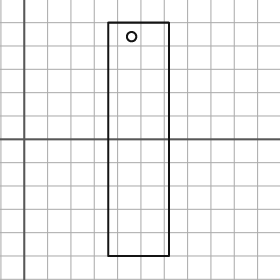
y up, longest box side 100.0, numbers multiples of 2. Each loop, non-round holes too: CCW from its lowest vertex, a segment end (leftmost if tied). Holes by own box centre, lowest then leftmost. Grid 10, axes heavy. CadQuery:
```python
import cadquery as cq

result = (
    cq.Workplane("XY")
    .moveTo(36.0, -50.0)
    .lineTo(62.0, -50.0)
    .lineTo(62.0, 50.0)
    .lineTo(36.0, 50.0)
    .close()
    .moveTo(46.0, 44.0)
    .circle(2.0)
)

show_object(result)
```